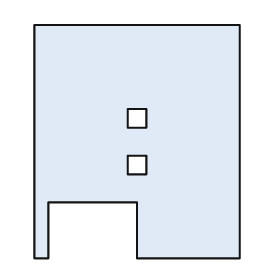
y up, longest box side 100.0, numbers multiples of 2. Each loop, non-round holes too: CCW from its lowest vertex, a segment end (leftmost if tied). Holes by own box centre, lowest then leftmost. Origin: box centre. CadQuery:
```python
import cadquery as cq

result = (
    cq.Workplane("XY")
    .moveTo(-44.0, -50.0)
    .lineTo(-38.0, -50.0)
    .lineTo(-38.0, -26.0)
    .lineTo(0.0, -26.0)
    .lineTo(0.0, -50.0)
    .lineTo(44.0, -50.0)
    .lineTo(44.0, 50.0)
    .lineTo(-44.0, 50.0)
    .close()
    .moveTo(-4.0, -14.0)
    .lineTo(4.0, -14.0)
    .lineTo(4.0, -6.0)
    .lineTo(-4.0, -6.0)
    .close()
    .moveTo(-4.0, 6.0)
    .lineTo(4.0, 6.0)
    .lineTo(4.0, 14.0)
    .lineTo(-4.0, 14.0)
    .close()
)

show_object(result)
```